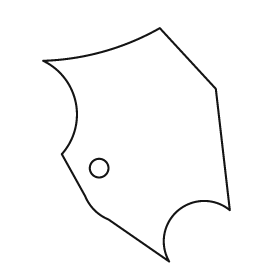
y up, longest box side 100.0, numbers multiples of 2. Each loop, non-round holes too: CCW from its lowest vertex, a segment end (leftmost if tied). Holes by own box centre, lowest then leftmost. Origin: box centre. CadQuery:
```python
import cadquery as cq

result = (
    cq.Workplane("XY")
    .moveTo(14.0, -50.0)
    .threePointArc((18.0, -28.0), (40.0, -28.0))
    .lineTo(34.0, 24.0)
    .lineTo(10.0, 50.0)
    .threePointArc((-14.0, 40.0), (-40.0, 36.0))
    .threePointArc((-26.0, 18.0), (-32.0, -4.0))
    .lineTo(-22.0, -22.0)
    .threePointArc((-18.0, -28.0), (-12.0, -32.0))
    .close()
    .moveTo(-16.0, -10.0)
    .circle(4.0)
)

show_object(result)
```